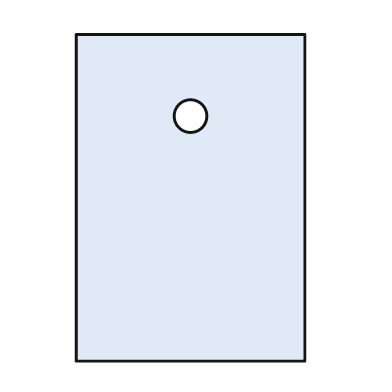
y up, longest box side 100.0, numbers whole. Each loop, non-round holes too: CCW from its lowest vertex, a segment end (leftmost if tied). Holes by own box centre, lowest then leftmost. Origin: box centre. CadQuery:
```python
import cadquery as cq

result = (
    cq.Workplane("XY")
    .moveTo(-35.0, -50.0)
    .lineTo(35.0, -50.0)
    .lineTo(35.0, 50.0)
    .lineTo(-35.0, 50.0)
    .close()
    .moveTo(0.0, 25.0)
    .circle(5.0)
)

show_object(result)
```